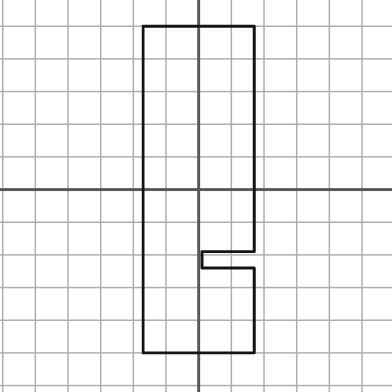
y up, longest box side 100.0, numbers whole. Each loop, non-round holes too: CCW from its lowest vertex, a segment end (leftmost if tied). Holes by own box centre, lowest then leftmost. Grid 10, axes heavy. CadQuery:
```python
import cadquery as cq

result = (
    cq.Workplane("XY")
    .moveTo(-17.0, -50.0)
    .lineTo(17.0, -50.0)
    .lineTo(17.0, -24.0)
    .lineTo(1.0, -24.0)
    .lineTo(1.0, -19.0)
    .lineTo(17.0, -19.0)
    .lineTo(17.0, 50.0)
    .lineTo(-17.0, 50.0)
    .close()
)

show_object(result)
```